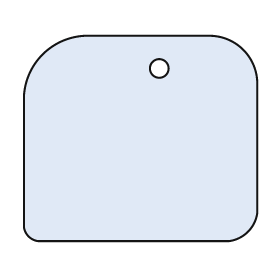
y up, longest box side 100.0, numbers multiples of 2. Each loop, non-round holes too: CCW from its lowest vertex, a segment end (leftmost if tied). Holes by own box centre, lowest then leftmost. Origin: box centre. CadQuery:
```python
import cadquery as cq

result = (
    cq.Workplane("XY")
    .moveTo(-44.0, -44.0)
    .lineTo(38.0, -44.0)
    .threePointArc((46.0, -40.0), (50.0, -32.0))
    .lineTo(50.0, 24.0)
    .threePointArc((44.0, 38.0), (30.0, 44.0))
    .lineTo(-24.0, 44.0)
    .threePointArc((-42.0, 36.0), (-50.0, 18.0))
    .lineTo(-50.0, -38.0)
    .threePointArc((-48.0, -42.0), (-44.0, -44.0))
    .close()
    .moveTo(8.0, 30.0)
    .circle(4.0)
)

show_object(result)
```